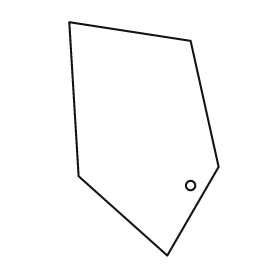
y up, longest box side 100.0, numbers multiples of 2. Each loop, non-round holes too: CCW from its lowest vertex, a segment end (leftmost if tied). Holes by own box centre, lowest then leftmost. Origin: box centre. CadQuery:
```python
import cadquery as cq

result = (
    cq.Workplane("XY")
    .moveTo(10.0, -50.0)
    .lineTo(32.0, -12.0)
    .lineTo(20.0, 42.0)
    .lineTo(-32.0, 50.0)
    .lineTo(-28.0, -16.0)
    .close()
    .moveTo(20.0, -20.0)
    .circle(2.0)
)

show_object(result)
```